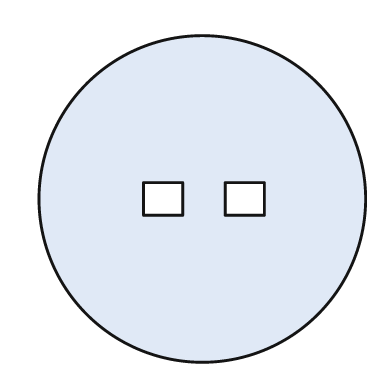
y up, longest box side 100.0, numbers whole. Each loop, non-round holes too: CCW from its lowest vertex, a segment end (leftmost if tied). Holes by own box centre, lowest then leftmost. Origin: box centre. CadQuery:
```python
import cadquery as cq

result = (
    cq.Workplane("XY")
    .moveTo(0.0, 0.0)
    .circle(50.0)
    .moveTo(-18.0, -5.0)
    .lineTo(-6.0, -5.0)
    .lineTo(-6.0, 5.0)
    .lineTo(-18.0, 5.0)
    .close()
    .moveTo(7.0, -5.0)
    .lineTo(19.0, -5.0)
    .lineTo(19.0, 5.0)
    .lineTo(7.0, 5.0)
    .close()
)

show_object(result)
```